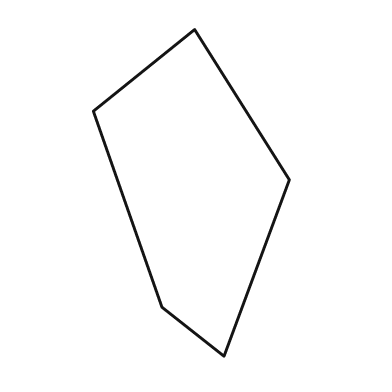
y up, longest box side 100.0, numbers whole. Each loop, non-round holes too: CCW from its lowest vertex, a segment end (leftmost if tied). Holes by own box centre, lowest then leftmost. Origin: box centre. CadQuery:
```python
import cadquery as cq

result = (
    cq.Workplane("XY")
    .moveTo(10.0, -50.0)
    .lineTo(30.0, 4.0)
    .lineTo(1.0, 50.0)
    .lineTo(-30.0, 25.0)
    .lineTo(-9.0, -35.0)
    .close()
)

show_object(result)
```